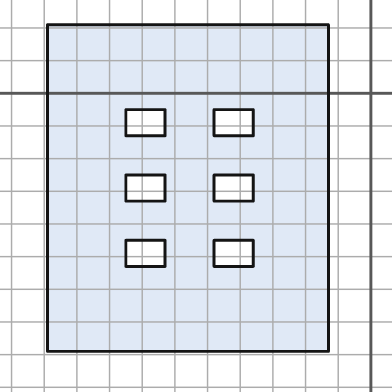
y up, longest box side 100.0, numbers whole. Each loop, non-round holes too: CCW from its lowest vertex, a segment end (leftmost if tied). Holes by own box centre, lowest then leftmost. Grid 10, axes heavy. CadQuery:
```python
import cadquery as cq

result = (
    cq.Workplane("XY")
    .moveTo(-99.0, -79.0)
    .lineTo(-13.0, -79.0)
    .lineTo(-13.0, 21.0)
    .lineTo(-99.0, 21.0)
    .close()
    .moveTo(-75.0, -53.0)
    .lineTo(-63.0, -53.0)
    .lineTo(-63.0, -45.0)
    .lineTo(-75.0, -45.0)
    .close()
    .moveTo(-48.0, -53.0)
    .lineTo(-36.0, -53.0)
    .lineTo(-36.0, -45.0)
    .lineTo(-48.0, -45.0)
    .close()
    .moveTo(-75.0, -33.0)
    .lineTo(-63.0, -33.0)
    .lineTo(-63.0, -25.0)
    .lineTo(-75.0, -25.0)
    .close()
    .moveTo(-48.0, -33.0)
    .lineTo(-36.0, -33.0)
    .lineTo(-36.0, -25.0)
    .lineTo(-48.0, -25.0)
    .close()
    .moveTo(-75.0, -13.0)
    .lineTo(-63.0, -13.0)
    .lineTo(-63.0, -5.0)
    .lineTo(-75.0, -5.0)
    .close()
    .moveTo(-48.0, -13.0)
    .lineTo(-36.0, -13.0)
    .lineTo(-36.0, -5.0)
    .lineTo(-48.0, -5.0)
    .close()
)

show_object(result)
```